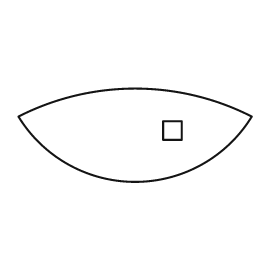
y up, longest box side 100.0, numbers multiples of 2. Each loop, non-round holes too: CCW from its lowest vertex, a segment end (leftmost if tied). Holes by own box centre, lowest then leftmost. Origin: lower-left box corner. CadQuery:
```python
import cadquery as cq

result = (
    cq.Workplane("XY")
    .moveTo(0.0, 28.0)
    .threePointArc((50.0, 0.0), (100.0, 28.0))
    .threePointArc((50.0, 40.0), (0.0, 28.0))
    .close()
    .moveTo(62.0, 18.0)
    .lineTo(70.0, 18.0)
    .lineTo(70.0, 26.0)
    .lineTo(62.0, 26.0)
    .close()
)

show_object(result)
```